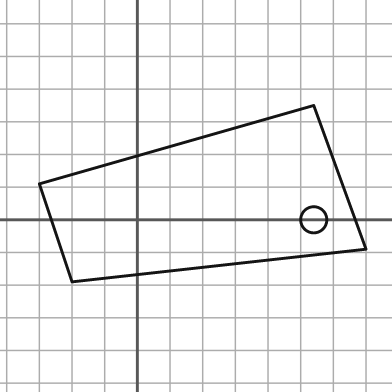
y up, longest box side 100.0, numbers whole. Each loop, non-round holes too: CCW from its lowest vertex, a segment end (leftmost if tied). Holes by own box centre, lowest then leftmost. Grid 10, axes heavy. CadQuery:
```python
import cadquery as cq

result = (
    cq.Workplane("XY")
    .moveTo(-20.0, -19.0)
    .lineTo(70.0, -9.0)
    .lineTo(54.0, 35.0)
    .lineTo(-30.0, 11.0)
    .close()
    .moveTo(54.0, 0.0)
    .circle(4.0)
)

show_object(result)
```